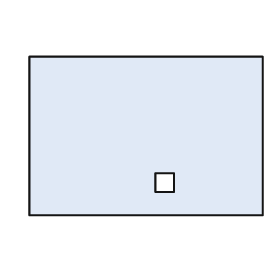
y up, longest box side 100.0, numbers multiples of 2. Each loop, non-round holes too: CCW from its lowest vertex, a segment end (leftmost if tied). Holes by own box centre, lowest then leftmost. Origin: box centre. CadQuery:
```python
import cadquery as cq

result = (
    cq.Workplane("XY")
    .moveTo(-50.0, -34.0)
    .lineTo(50.0, -34.0)
    .lineTo(50.0, 34.0)
    .lineTo(-50.0, 34.0)
    .close()
    .moveTo(4.0, -24.0)
    .lineTo(12.0, -24.0)
    .lineTo(12.0, -16.0)
    .lineTo(4.0, -16.0)
    .close()
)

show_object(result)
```